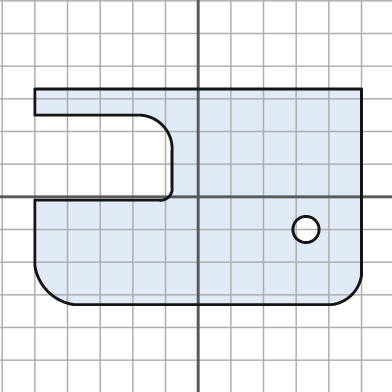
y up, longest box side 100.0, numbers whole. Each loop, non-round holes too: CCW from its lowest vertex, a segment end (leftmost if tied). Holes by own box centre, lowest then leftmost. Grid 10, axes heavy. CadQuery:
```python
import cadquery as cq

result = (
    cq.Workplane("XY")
    .moveTo(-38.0, -33.0)
    .lineTo(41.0, -33.0)
    .threePointArc((47.0, -30.0), (50.0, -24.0))
    .lineTo(50.0, 33.0)
    .lineTo(-50.0, 33.0)
    .lineTo(-50.0, 25.0)
    .lineTo(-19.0, 25.0)
    .threePointArc((-11.0, 22.0), (-8.0, 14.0))
    .lineTo(-8.0, 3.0)
    .threePointArc((-9.0, 0.0), (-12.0, -1.0))
    .lineTo(-50.0, -1.0)
    .lineTo(-50.0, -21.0)
    .threePointArc((-46.0, -29.0), (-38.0, -33.0))
    .close()
    .moveTo(33.0, -10.0)
    .circle(4.0)
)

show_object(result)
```